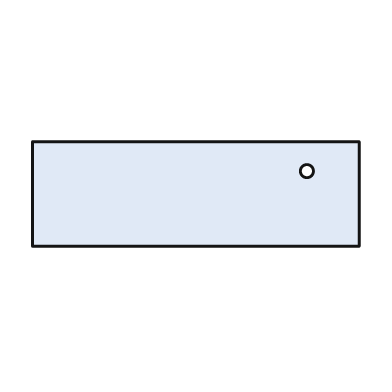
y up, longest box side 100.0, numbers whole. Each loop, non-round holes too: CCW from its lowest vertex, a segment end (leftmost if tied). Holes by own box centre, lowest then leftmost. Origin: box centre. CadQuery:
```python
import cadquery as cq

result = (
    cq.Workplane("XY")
    .moveTo(-50.0, -16.0)
    .lineTo(50.0, -16.0)
    .lineTo(50.0, 16.0)
    .lineTo(-50.0, 16.0)
    .close()
    .moveTo(34.0, 7.0)
    .circle(2.0)
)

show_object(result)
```